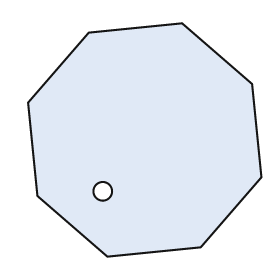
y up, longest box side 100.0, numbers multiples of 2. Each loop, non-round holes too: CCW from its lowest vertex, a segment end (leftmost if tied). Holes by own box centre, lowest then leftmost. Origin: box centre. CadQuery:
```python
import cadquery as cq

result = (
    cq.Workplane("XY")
    .moveTo(-16.0, -50.0)
    .lineTo(24.0, -46.0)
    .lineTo(50.0, -16.0)
    .lineTo(46.0, 24.0)
    .lineTo(16.0, 50.0)
    .lineTo(-24.0, 46.0)
    .lineTo(-50.0, 16.0)
    .lineTo(-46.0, -24.0)
    .close()
    .moveTo(-18.0, -22.0)
    .circle(4.0)
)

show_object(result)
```